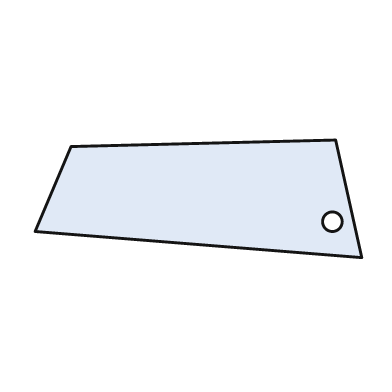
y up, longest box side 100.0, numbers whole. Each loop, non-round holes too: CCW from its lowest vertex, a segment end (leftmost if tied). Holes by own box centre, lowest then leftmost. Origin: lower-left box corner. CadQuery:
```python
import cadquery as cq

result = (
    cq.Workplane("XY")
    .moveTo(100.0, 0.0)
    .lineTo(92.0, 36.0)
    .lineTo(11.0, 34.0)
    .lineTo(0.0, 8.0)
    .close()
    .moveTo(91.0, 11.0)
    .circle(3.0)
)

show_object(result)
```